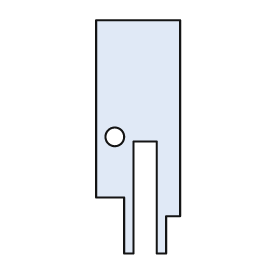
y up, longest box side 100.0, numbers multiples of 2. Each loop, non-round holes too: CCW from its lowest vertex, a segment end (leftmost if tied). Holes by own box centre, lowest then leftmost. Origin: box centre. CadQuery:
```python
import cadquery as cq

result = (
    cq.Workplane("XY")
    .moveTo(-6.0, -50.0)
    .lineTo(-2.0, -50.0)
    .lineTo(-2.0, -2.0)
    .lineTo(8.0, -2.0)
    .lineTo(8.0, -50.0)
    .lineTo(12.0, -50.0)
    .lineTo(12.0, -34.0)
    .lineTo(18.0, -34.0)
    .lineTo(18.0, 50.0)
    .lineTo(-18.0, 50.0)
    .lineTo(-18.0, -26.0)
    .lineTo(-6.0, -26.0)
    .close()
    .moveTo(-10.0, 0.0)
    .circle(4.0)
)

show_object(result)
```